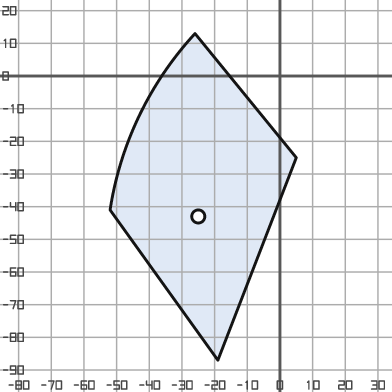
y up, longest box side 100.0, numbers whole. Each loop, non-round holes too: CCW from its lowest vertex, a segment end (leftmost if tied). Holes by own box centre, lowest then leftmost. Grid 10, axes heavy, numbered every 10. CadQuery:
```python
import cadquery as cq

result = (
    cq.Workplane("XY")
    .moveTo(-19.0, -87.0)
    .lineTo(5.0, -25.0)
    .lineTo(-26.0, 13.0)
    .threePointArc((-43.0, -12.0), (-52.0, -41.0))
    .close()
    .moveTo(-25.0, -43.0)
    .circle(2.0)
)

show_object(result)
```